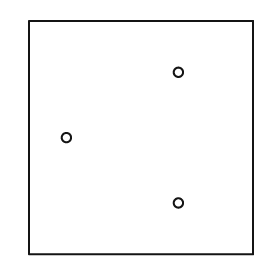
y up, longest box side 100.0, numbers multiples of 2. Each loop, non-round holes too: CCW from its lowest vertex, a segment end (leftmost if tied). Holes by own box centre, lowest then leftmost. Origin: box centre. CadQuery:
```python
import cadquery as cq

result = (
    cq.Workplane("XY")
    .moveTo(-48.0, -50.0)
    .lineTo(48.0, -50.0)
    .lineTo(48.0, 50.0)
    .lineTo(-48.0, 50.0)
    .close()
    .moveTo(16.0, -28.0)
    .circle(2.0)
    .moveTo(-32.0, 0.0)
    .circle(2.0)
    .moveTo(16.0, 28.0)
    .circle(2.0)
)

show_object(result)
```